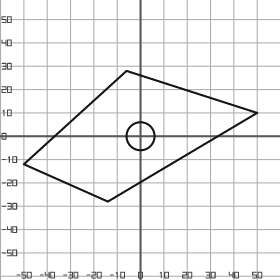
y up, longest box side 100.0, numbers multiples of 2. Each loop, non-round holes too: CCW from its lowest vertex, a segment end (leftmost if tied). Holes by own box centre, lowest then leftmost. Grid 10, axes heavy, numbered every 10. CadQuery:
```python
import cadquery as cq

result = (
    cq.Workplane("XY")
    .moveTo(-14.0, -28.0)
    .lineTo(50.0, 10.0)
    .lineTo(-6.0, 28.0)
    .lineTo(-50.0, -12.0)
    .close()
    .moveTo(0.0, 0.0)
    .circle(6.0)
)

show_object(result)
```